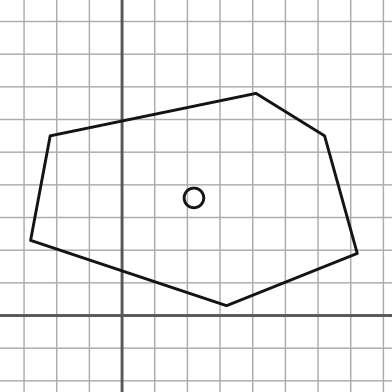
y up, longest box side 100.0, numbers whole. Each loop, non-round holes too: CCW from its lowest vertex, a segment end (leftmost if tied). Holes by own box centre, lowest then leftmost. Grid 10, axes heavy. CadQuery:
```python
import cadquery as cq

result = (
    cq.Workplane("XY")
    .moveTo(32.0, 3.0)
    .lineTo(72.0, 19.0)
    .lineTo(62.0, 55.0)
    .lineTo(41.0, 68.0)
    .lineTo(-22.0, 55.0)
    .lineTo(-28.0, 23.0)
    .close()
    .moveTo(22.0, 36.0)
    .circle(3.0)
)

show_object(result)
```